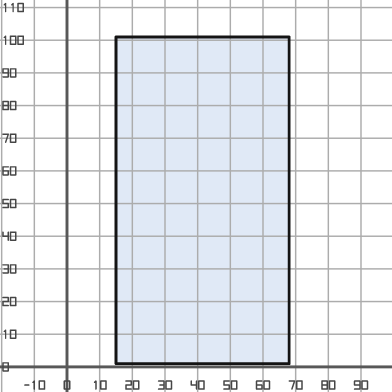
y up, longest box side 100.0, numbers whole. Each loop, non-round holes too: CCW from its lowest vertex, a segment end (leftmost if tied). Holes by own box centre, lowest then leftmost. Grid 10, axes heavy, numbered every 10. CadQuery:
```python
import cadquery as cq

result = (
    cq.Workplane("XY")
    .moveTo(15.0, 1.0)
    .lineTo(68.0, 1.0)
    .lineTo(68.0, 101.0)
    .lineTo(15.0, 101.0)
    .close()
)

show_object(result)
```